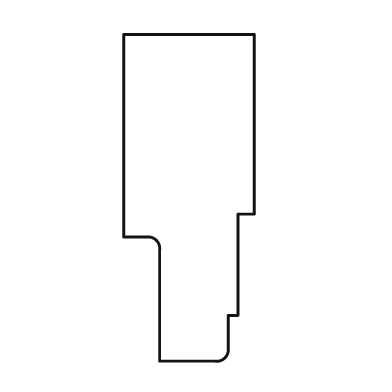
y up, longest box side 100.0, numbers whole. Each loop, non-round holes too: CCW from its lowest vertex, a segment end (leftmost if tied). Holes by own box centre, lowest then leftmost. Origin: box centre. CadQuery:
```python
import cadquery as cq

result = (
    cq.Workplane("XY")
    .moveTo(-9.0, -50.0)
    .lineTo(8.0, -50.0)
    .threePointArc((11.0, -49.0), (12.0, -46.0))
    .lineTo(12.0, -36.0)
    .lineTo(15.0, -36.0)
    .lineTo(15.0, -5.0)
    .lineTo(20.0, -5.0)
    .lineTo(20.0, 50.0)
    .lineTo(-20.0, 50.0)
    .lineTo(-20.0, -12.0)
    .lineTo(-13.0, -12.0)
    .threePointArc((-10.0, -13.0), (-9.0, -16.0))
    .close()
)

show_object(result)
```